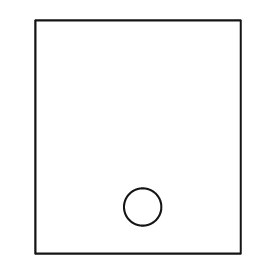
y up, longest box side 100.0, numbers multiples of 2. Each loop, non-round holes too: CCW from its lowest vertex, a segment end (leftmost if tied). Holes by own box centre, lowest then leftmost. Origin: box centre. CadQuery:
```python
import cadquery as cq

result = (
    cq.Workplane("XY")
    .moveTo(-44.0, -50.0)
    .lineTo(44.0, -50.0)
    .lineTo(44.0, 50.0)
    .lineTo(-44.0, 50.0)
    .close()
    .moveTo(2.0, -30.0)
    .circle(8.0)
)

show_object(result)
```